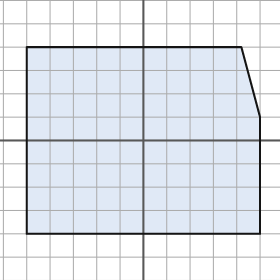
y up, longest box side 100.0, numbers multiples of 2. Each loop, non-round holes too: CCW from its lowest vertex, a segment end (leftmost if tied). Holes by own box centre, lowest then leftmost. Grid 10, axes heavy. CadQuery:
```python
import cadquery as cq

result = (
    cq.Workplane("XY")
    .moveTo(-50.0, -40.0)
    .lineTo(50.0, -40.0)
    .lineTo(50.0, 10.0)
    .lineTo(42.0, 40.0)
    .lineTo(-50.0, 40.0)
    .close()
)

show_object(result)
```